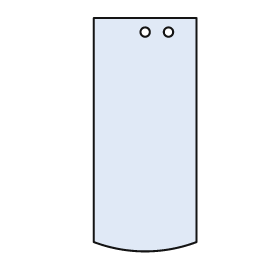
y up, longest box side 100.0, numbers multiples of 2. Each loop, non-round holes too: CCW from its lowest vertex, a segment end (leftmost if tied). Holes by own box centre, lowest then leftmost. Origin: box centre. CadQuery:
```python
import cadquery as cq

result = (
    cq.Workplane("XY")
    .moveTo(-22.0, -46.0)
    .threePointArc((0.0, -50.0), (22.0, -46.0))
    .lineTo(22.0, 50.0)
    .lineTo(-22.0, 50.0)
    .close()
    .moveTo(0.0, 44.0)
    .circle(2.0)
    .moveTo(10.0, 44.0)
    .circle(2.0)
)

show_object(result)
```